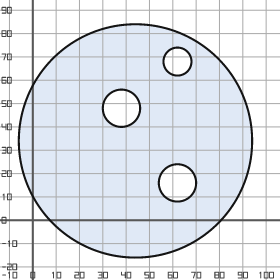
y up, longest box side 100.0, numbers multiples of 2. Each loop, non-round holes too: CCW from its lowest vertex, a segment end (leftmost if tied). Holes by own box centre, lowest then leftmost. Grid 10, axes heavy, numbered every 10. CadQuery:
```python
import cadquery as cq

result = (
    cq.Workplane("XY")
    .moveTo(44.0, 34.0)
    .circle(50.0)
    .moveTo(62.0, 16.0)
    .circle(8.0)
    .moveTo(38.0, 48.0)
    .circle(8.0)
    .moveTo(62.0, 68.0)
    .circle(6.0)
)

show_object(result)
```